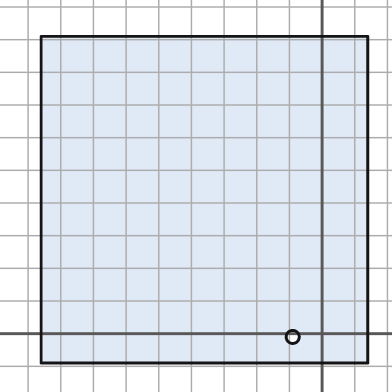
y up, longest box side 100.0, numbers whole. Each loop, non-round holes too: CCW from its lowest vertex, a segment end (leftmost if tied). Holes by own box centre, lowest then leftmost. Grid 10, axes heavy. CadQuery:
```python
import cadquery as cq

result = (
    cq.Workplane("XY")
    .moveTo(-86.0, -9.0)
    .lineTo(14.0, -9.0)
    .lineTo(14.0, 91.0)
    .lineTo(-86.0, 91.0)
    .close()
    .moveTo(-9.0, -1.0)
    .circle(2.0)
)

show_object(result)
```